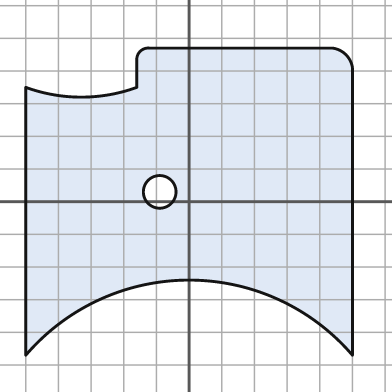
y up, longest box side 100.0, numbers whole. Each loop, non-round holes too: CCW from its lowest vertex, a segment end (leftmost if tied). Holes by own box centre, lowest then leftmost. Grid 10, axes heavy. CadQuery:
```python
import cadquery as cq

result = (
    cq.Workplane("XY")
    .moveTo(-50.0, -47.0)
    .threePointArc((0.0, -24.0), (50.0, -47.0))
    .lineTo(50.0, 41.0)
    .threePointArc((48.0, 45.0), (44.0, 47.0))
    .lineTo(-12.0, 47.0)
    .threePointArc((-15.0, 46.0), (-16.0, 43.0))
    .lineTo(-16.0, 35.0)
    .threePointArc((-33.0, 32.0), (-50.0, 35.0))
    .close()
    .moveTo(-9.0, 3.0)
    .circle(5.0)
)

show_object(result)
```